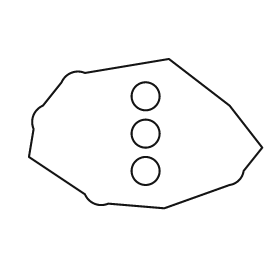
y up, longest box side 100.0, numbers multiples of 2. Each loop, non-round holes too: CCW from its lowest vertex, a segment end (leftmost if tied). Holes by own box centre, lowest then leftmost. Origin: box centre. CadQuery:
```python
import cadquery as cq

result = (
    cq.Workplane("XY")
    .moveTo(8.0, -32.0)
    .lineTo(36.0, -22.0)
    .threePointArc((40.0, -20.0), (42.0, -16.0))
    .lineTo(50.0, -6.0)
    .lineTo(36.0, 12.0)
    .lineTo(10.0, 32.0)
    .lineTo(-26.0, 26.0)
    .threePointArc((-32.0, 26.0), (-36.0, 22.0))
    .lineTo(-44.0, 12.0)
    .threePointArc((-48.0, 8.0), (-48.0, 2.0))
    .lineTo(-50.0, -10.0)
    .lineTo(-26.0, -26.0)
    .threePointArc((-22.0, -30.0), (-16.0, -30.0))
    .close()
    .moveTo(0.0, -16.0)
    .circle(6.0)
    .moveTo(0.0, 0.0)
    .circle(6.0)
    .moveTo(0.0, 16.0)
    .circle(6.0)
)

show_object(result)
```